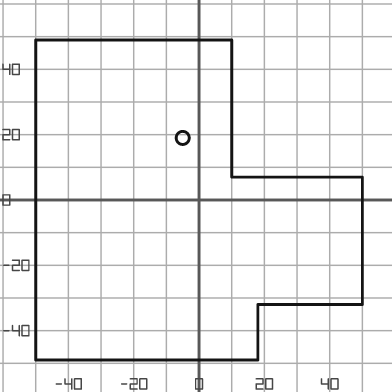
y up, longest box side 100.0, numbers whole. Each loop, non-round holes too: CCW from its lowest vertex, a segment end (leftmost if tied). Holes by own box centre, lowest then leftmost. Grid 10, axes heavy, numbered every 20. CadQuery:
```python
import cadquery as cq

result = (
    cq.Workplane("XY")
    .moveTo(-50.0, -49.0)
    .lineTo(18.0, -49.0)
    .lineTo(18.0, -32.0)
    .lineTo(50.0, -32.0)
    .lineTo(50.0, 7.0)
    .lineTo(10.0, 7.0)
    .lineTo(10.0, 49.0)
    .lineTo(-50.0, 49.0)
    .close()
    .moveTo(-5.0, 19.0)
    .circle(2.0)
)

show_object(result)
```